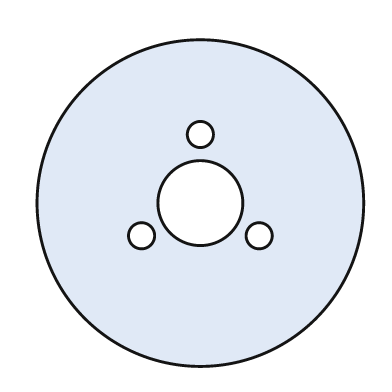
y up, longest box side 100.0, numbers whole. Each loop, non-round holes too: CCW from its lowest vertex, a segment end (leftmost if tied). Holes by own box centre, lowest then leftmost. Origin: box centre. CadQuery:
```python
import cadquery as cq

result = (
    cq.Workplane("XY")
    .moveTo(0.0, 0.0)
    .circle(50.0)
    .moveTo(-18.0, -10.0)
    .circle(4.0)
    .moveTo(18.0, -10.0)
    .circle(4.0)
    .moveTo(0.0, 0.0)
    .circle(13.0)
    .moveTo(0.0, 21.0)
    .circle(4.0)
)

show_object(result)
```